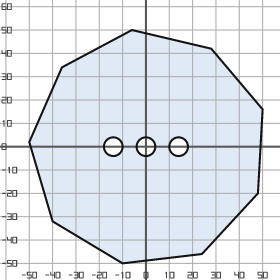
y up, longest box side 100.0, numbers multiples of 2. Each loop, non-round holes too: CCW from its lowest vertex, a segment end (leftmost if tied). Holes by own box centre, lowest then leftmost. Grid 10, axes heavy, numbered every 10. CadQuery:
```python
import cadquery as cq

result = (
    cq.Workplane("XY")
    .moveTo(-10.0, -50.0)
    .lineTo(24.0, -46.0)
    .lineTo(48.0, -20.0)
    .lineTo(50.0, 16.0)
    .lineTo(28.0, 42.0)
    .lineTo(-6.0, 50.0)
    .lineTo(-36.0, 34.0)
    .lineTo(-50.0, 2.0)
    .lineTo(-40.0, -32.0)
    .close()
    .moveTo(-14.0, 0.0)
    .circle(4.0)
    .moveTo(0.0, 0.0)
    .circle(4.0)
    .moveTo(14.0, 0.0)
    .circle(4.0)
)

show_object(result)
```